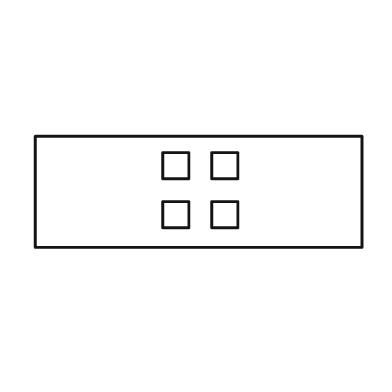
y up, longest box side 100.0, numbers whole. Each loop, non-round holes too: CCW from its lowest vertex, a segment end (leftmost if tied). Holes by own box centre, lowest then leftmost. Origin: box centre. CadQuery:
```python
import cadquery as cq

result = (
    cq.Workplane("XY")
    .moveTo(-50.0, -17.0)
    .lineTo(50.0, -17.0)
    .lineTo(50.0, 17.0)
    .lineTo(-50.0, 17.0)
    .close()
    .moveTo(-11.0, -11.0)
    .lineTo(-3.0, -11.0)
    .lineTo(-3.0, -3.0)
    .lineTo(-11.0, -3.0)
    .close()
    .moveTo(4.0, -11.0)
    .lineTo(12.0, -11.0)
    .lineTo(12.0, -3.0)
    .lineTo(4.0, -3.0)
    .close()
    .moveTo(-11.0, 4.0)
    .lineTo(-3.0, 4.0)
    .lineTo(-3.0, 12.0)
    .lineTo(-11.0, 12.0)
    .close()
    .moveTo(4.0, 4.0)
    .lineTo(12.0, 4.0)
    .lineTo(12.0, 12.0)
    .lineTo(4.0, 12.0)
    .close()
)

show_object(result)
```